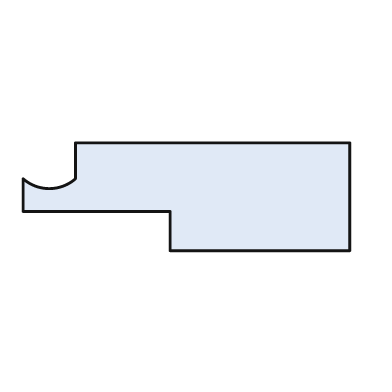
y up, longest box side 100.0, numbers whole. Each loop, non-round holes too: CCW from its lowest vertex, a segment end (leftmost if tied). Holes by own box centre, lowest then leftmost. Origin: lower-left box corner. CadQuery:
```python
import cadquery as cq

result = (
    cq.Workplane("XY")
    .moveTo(45.0, 0.0)
    .lineTo(100.0, 0.0)
    .lineTo(100.0, 33.0)
    .lineTo(16.0, 33.0)
    .lineTo(16.0, 22.0)
    .threePointArc((8.0, 19.0), (0.0, 22.0))
    .lineTo(0.0, 12.0)
    .lineTo(45.0, 12.0)
    .close()
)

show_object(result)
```